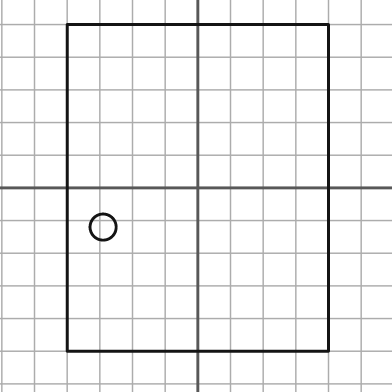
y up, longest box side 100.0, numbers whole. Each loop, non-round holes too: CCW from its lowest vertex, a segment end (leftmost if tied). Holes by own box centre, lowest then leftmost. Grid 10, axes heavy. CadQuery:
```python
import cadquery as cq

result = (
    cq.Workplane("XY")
    .moveTo(-40.0, -50.0)
    .lineTo(40.0, -50.0)
    .lineTo(40.0, 50.0)
    .lineTo(-40.0, 50.0)
    .close()
    .moveTo(-29.0, -12.0)
    .circle(4.0)
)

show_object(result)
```